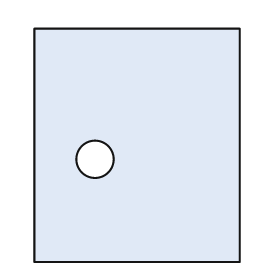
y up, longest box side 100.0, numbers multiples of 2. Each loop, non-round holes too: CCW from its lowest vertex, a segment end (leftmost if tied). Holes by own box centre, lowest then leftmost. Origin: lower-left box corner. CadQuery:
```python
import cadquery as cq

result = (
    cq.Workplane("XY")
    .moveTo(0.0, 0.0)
    .lineTo(88.0, 0.0)
    .lineTo(88.0, 100.0)
    .lineTo(0.0, 100.0)
    .close()
    .moveTo(26.0, 44.0)
    .circle(8.0)
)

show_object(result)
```